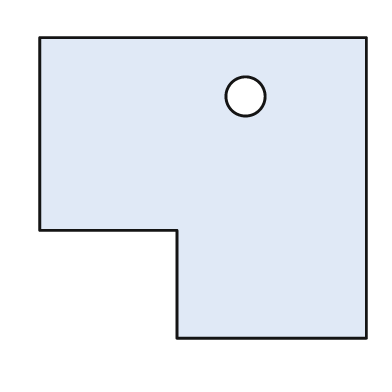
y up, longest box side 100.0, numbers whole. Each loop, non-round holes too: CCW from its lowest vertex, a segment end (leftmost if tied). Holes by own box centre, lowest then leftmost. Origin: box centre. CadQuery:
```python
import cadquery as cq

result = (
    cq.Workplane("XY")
    .moveTo(-8.0, -46.0)
    .lineTo(50.0, -46.0)
    .lineTo(50.0, 46.0)
    .lineTo(-50.0, 46.0)
    .lineTo(-50.0, -13.0)
    .lineTo(-8.0, -13.0)
    .close()
    .moveTo(13.0, 28.0)
    .circle(6.0)
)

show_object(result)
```